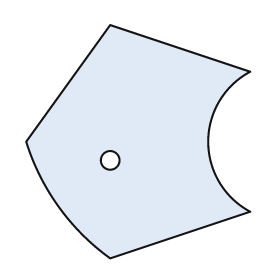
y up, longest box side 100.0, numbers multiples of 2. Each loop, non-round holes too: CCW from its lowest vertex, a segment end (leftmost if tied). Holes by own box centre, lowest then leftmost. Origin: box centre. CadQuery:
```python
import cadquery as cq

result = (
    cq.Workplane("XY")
    .moveTo(-12.0, -50.0)
    .lineTo(48.0, -30.0)
    .threePointArc((30.0, 0.0), (48.0, 30.0))
    .lineTo(-12.0, 50.0)
    .lineTo(-48.0, 0.0)
    .threePointArc((-34.0, -28.0), (-12.0, -50.0))
    .close()
    .moveTo(-12.0, -8.0)
    .circle(4.0)
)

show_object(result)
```